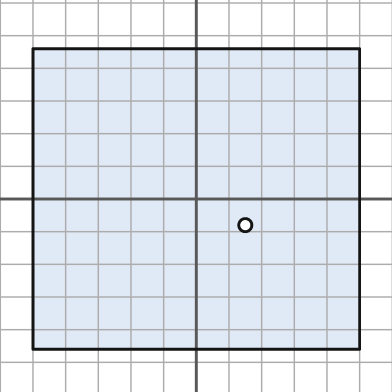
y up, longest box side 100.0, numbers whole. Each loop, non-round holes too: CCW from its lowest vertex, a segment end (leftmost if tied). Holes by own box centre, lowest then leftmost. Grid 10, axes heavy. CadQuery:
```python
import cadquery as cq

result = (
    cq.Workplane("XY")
    .moveTo(-50.0, -46.0)
    .lineTo(50.0, -46.0)
    .lineTo(50.0, 46.0)
    .lineTo(-50.0, 46.0)
    .close()
    .moveTo(15.0, -8.0)
    .circle(2.0)
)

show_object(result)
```